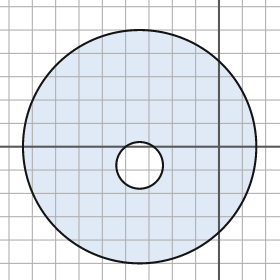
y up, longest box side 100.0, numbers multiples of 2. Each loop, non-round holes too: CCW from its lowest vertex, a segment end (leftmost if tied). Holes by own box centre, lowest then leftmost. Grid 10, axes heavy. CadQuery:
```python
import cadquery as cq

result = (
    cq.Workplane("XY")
    .moveTo(-34.0, 0.0)
    .circle(50.0)
    .moveTo(-34.0, -8.0)
    .circle(10.0)
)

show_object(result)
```